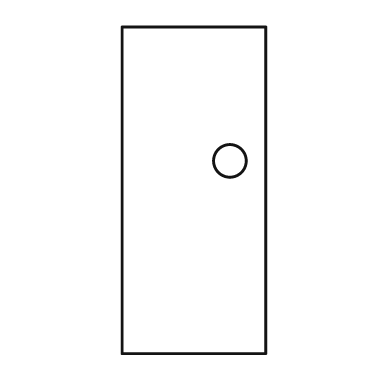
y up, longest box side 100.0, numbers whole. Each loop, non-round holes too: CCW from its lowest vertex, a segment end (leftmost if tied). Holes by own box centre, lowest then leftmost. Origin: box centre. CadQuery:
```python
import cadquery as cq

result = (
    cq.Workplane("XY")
    .moveTo(-22.0, -50.0)
    .lineTo(22.0, -50.0)
    .lineTo(22.0, 50.0)
    .lineTo(-22.0, 50.0)
    .close()
    .moveTo(11.0, 9.0)
    .circle(5.0)
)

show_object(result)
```